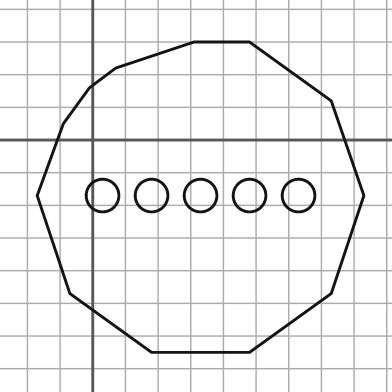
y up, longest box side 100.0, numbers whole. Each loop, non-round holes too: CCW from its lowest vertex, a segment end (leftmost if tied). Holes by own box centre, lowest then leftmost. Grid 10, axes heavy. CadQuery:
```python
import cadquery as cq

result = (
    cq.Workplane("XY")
    .moveTo(18.0, -65.0)
    .lineTo(48.0, -65.0)
    .lineTo(73.0, -47.0)
    .lineTo(83.0, -17.0)
    .lineTo(73.0, 12.0)
    .lineTo(48.0, 30.0)
    .lineTo(31.0, 30.0)
    .lineTo(7.0, 22.0)
    .lineTo(-1.0, 16.0)
    .lineTo(-9.0, 5.0)
    .lineTo(-17.0, -17.0)
    .lineTo(-7.0, -47.0)
    .close()
    .moveTo(3.0, -17.0)
    .circle(5.0)
    .moveTo(18.0, -17.0)
    .circle(5.0)
    .moveTo(33.0, -17.0)
    .circle(5.0)
    .moveTo(48.0, -17.0)
    .circle(5.0)
    .moveTo(63.0, -17.0)
    .circle(5.0)
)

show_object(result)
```